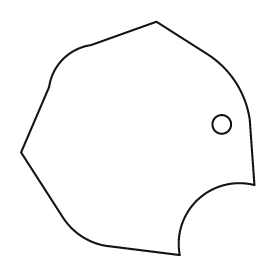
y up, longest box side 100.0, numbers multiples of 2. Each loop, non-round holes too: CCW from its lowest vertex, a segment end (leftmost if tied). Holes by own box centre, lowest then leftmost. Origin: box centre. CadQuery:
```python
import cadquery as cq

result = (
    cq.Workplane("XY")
    .moveTo(18.0, -50.0)
    .threePointArc((26.0, -26.0), (50.0, -20.0))
    .lineTo(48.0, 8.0)
    .threePointArc((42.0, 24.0), (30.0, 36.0))
    .lineTo(8.0, 50.0)
    .lineTo(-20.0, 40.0)
    .threePointArc((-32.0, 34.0), (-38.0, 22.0))
    .lineTo(-50.0, -6.0)
    .lineTo(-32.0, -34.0)
    .threePointArc((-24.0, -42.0), (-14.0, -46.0))
    .close()
    .moveTo(36.0, 6.0)
    .circle(4.0)
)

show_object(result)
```